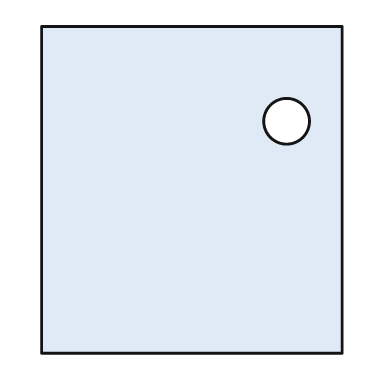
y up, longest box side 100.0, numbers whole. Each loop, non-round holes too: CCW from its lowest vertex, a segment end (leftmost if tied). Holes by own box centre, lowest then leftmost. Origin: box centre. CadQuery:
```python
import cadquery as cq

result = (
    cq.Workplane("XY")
    .moveTo(-46.0, -50.0)
    .lineTo(46.0, -50.0)
    .lineTo(46.0, 50.0)
    .lineTo(-46.0, 50.0)
    .close()
    .moveTo(29.0, 21.0)
    .circle(7.0)
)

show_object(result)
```